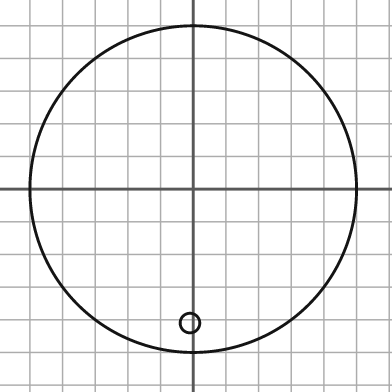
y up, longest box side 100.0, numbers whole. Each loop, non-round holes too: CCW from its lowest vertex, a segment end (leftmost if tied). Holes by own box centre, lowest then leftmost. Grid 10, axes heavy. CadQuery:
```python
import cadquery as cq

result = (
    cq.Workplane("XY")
    .moveTo(0.0, 0.0)
    .circle(50.0)
    .moveTo(-1.0, -41.0)
    .circle(3.0)
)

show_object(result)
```